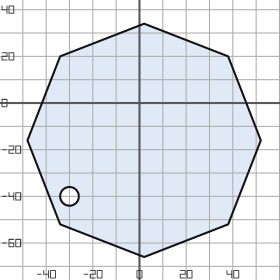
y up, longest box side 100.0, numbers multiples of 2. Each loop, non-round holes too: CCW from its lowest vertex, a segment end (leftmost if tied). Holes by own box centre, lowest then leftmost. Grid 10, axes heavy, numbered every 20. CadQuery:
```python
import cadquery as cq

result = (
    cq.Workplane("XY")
    .moveTo(2.0, -66.0)
    .lineTo(38.0, -52.0)
    .lineTo(52.0, -16.0)
    .lineTo(38.0, 20.0)
    .lineTo(2.0, 34.0)
    .lineTo(-34.0, 20.0)
    .lineTo(-48.0, -16.0)
    .lineTo(-34.0, -52.0)
    .close()
    .moveTo(-30.0, -40.0)
    .circle(4.0)
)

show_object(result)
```